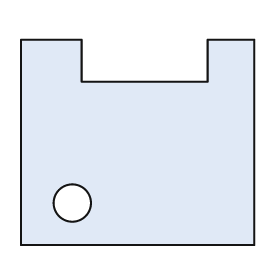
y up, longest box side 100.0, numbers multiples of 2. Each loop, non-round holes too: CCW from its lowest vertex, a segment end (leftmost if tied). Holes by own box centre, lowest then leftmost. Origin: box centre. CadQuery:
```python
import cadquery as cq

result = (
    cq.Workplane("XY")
    .moveTo(-50.0, -44.0)
    .lineTo(50.0, -44.0)
    .lineTo(50.0, 44.0)
    .lineTo(30.0, 44.0)
    .lineTo(30.0, 26.0)
    .lineTo(-24.0, 26.0)
    .lineTo(-24.0, 44.0)
    .lineTo(-50.0, 44.0)
    .close()
    .moveTo(-28.0, -26.0)
    .circle(8.0)
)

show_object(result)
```